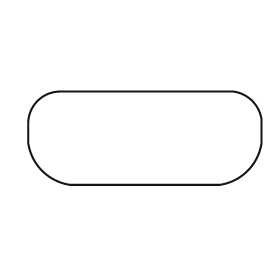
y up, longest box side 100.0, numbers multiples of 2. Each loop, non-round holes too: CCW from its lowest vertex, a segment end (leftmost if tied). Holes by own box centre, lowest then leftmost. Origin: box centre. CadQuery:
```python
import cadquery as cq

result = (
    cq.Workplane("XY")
    .moveTo(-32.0, -20.0)
    .lineTo(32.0, -20.0)
    .threePointArc((44.0, -14.0), (50.0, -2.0))
    .lineTo(50.0, 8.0)
    .threePointArc((46.0, 16.0), (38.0, 20.0))
    .lineTo(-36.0, 20.0)
    .threePointArc((-46.0, 16.0), (-50.0, 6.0))
    .lineTo(-50.0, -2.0)
    .threePointArc((-44.0, -14.0), (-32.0, -20.0))
    .close()
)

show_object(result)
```